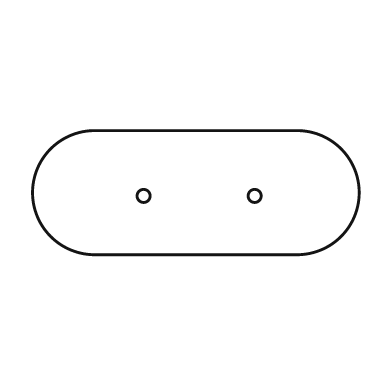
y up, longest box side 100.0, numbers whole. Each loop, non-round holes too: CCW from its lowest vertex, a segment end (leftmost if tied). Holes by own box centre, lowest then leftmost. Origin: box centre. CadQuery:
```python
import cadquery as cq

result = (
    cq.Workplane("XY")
    .moveTo(-31.0, -19.0)
    .lineTo(31.0, -19.0)
    .threePointArc((50.0, 0.0), (31.0, 19.0))
    .lineTo(-31.0, 19.0)
    .threePointArc((-50.0, 0.0), (-31.0, -19.0))
    .close()
    .moveTo(-16.0, -1.0)
    .circle(2.0)
    .moveTo(18.0, -1.0)
    .circle(2.0)
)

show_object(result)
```